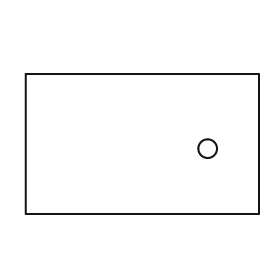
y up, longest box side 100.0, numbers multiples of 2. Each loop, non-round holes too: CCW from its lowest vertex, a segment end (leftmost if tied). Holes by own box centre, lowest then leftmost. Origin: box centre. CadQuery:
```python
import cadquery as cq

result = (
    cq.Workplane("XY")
    .moveTo(-50.0, -30.0)
    .lineTo(50.0, -30.0)
    .lineTo(50.0, 30.0)
    .lineTo(-50.0, 30.0)
    .close()
    .moveTo(28.0, -2.0)
    .circle(4.0)
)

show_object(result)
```